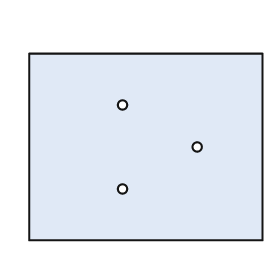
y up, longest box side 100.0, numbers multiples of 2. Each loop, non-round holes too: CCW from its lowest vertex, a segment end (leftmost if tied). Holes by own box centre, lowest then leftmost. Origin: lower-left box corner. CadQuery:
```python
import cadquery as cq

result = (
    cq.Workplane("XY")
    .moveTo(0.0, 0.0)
    .lineTo(100.0, 0.0)
    .lineTo(100.0, 80.0)
    .lineTo(0.0, 80.0)
    .close()
    .moveTo(40.0, 22.0)
    .circle(2.0)
    .moveTo(72.0, 40.0)
    .circle(2.0)
    .moveTo(40.0, 58.0)
    .circle(2.0)
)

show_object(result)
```